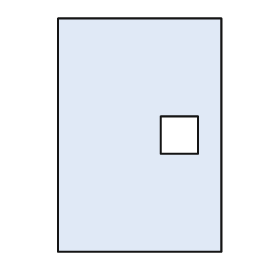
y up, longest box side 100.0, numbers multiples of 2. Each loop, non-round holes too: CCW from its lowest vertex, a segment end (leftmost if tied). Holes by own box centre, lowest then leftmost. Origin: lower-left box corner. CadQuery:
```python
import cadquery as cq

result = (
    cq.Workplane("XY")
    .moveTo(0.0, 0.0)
    .lineTo(70.0, 0.0)
    .lineTo(70.0, 100.0)
    .lineTo(0.0, 100.0)
    .close()
    .moveTo(44.0, 42.0)
    .lineTo(60.0, 42.0)
    .lineTo(60.0, 58.0)
    .lineTo(44.0, 58.0)
    .close()
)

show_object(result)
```